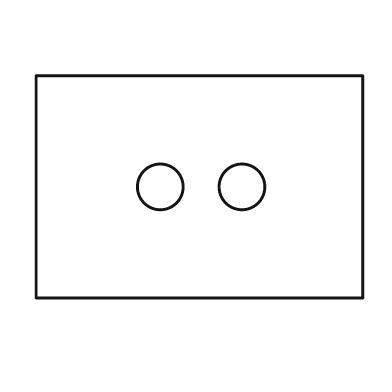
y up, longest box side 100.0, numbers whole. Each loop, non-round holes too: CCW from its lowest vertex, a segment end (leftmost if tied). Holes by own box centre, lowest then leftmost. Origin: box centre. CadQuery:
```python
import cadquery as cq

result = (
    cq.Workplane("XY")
    .moveTo(-50.0, -34.0)
    .lineTo(50.0, -34.0)
    .lineTo(50.0, 34.0)
    .lineTo(-50.0, 34.0)
    .close()
    .moveTo(-12.0, 0.0)
    .circle(7.0)
    .moveTo(13.0, 0.0)
    .circle(7.0)
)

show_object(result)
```